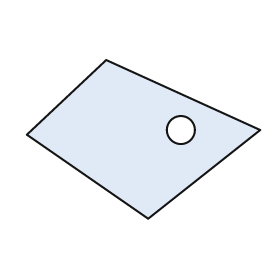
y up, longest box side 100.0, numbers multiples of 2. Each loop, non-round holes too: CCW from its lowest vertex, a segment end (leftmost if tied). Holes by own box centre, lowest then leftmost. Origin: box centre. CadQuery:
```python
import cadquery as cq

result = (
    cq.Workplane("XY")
    .moveTo(2.0, -34.0)
    .lineTo(50.0, 4.0)
    .lineTo(-16.0, 34.0)
    .lineTo(-50.0, 2.0)
    .close()
    .moveTo(16.0, 4.0)
    .circle(6.0)
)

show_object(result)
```